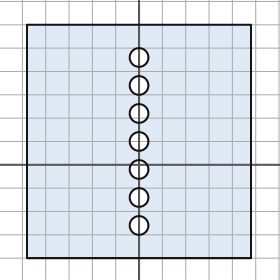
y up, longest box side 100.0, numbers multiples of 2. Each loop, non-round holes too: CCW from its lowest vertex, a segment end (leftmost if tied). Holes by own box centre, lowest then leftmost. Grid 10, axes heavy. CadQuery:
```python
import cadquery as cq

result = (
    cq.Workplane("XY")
    .moveTo(-48.0, -40.0)
    .lineTo(48.0, -40.0)
    .lineTo(48.0, 60.0)
    .lineTo(-48.0, 60.0)
    .close()
    .moveTo(0.0, -26.0)
    .circle(4.0)
    .moveTo(0.0, -14.0)
    .circle(4.0)
    .moveTo(0.0, -2.0)
    .circle(4.0)
    .moveTo(0.0, 10.0)
    .circle(4.0)
    .moveTo(0.0, 22.0)
    .circle(4.0)
    .moveTo(0.0, 34.0)
    .circle(4.0)
    .moveTo(0.0, 46.0)
    .circle(4.0)
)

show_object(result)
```